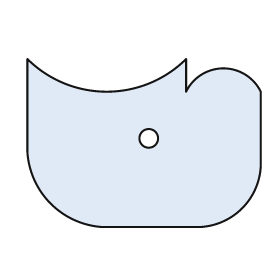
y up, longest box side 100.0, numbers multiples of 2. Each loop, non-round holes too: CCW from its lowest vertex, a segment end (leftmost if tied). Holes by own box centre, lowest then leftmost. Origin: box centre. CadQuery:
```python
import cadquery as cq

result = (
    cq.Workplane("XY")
    .moveTo(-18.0, -36.0)
    .lineTo(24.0, -36.0)
    .threePointArc((42.0, -28.0), (50.0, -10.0))
    .lineTo(50.0, 22.0)
    .threePointArc((34.0, 32.0), (18.0, 22.0))
    .lineTo(18.0, 36.0)
    .threePointArc((-16.0, 22.0), (-50.0, 36.0))
    .lineTo(-50.0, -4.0)
    .threePointArc((-40.0, -26.0), (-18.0, -36.0))
    .close()
    .moveTo(2.0, 2.0)
    .circle(4.0)
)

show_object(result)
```